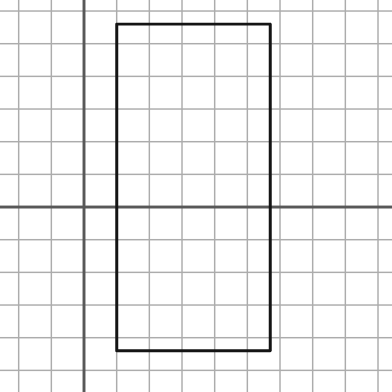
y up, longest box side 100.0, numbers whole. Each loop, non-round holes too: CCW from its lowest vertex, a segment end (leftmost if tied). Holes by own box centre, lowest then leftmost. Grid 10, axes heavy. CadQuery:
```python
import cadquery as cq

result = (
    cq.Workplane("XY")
    .moveTo(10.0, -44.0)
    .lineTo(57.0, -44.0)
    .lineTo(57.0, 56.0)
    .lineTo(10.0, 56.0)
    .close()
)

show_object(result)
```